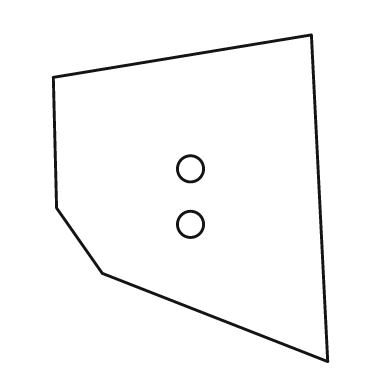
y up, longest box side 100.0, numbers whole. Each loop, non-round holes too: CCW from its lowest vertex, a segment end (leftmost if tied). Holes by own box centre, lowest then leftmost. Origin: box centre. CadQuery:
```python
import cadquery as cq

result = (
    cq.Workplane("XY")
    .moveTo(42.0, -50.0)
    .lineTo(37.0, 50.0)
    .lineTo(-42.0, 37.0)
    .lineTo(-41.0, -3.0)
    .lineTo(-27.0, -23.0)
    .close()
    .moveTo(0.0, -8.0)
    .circle(4.0)
    .moveTo(0.0, 9.0)
    .circle(4.0)
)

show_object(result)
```